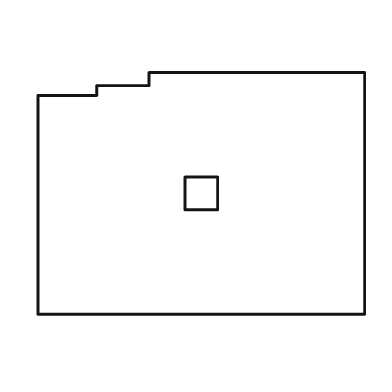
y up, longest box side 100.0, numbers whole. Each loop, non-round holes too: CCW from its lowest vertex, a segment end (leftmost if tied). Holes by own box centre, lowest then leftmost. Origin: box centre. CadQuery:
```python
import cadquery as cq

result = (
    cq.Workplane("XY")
    .moveTo(-50.0, -37.0)
    .lineTo(50.0, -37.0)
    .lineTo(50.0, 37.0)
    .lineTo(-16.0, 37.0)
    .lineTo(-16.0, 33.0)
    .lineTo(-32.0, 33.0)
    .lineTo(-32.0, 30.0)
    .lineTo(-50.0, 30.0)
    .close()
    .moveTo(-5.0, -5.0)
    .lineTo(5.0, -5.0)
    .lineTo(5.0, 5.0)
    .lineTo(-5.0, 5.0)
    .close()
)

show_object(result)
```